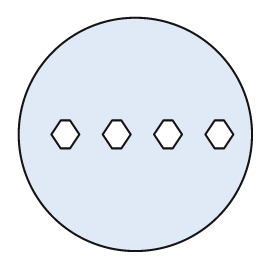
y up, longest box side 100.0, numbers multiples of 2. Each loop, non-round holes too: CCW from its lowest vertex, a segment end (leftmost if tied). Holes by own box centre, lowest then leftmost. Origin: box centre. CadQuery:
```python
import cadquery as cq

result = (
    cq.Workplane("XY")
    .moveTo(0.0, 0.0)
    .circle(50.0)
    .moveTo(-32.0, -6.0)
    .lineTo(-28.0, -6.0)
    .lineTo(-24.0, 0.0)
    .lineTo(-28.0, 6.0)
    .lineTo(-32.0, 6.0)
    .lineTo(-36.0, 0.0)
    .close()
    .moveTo(-10.0, -6.0)
    .lineTo(-6.0, -6.0)
    .lineTo(-2.0, 0.0)
    .lineTo(-6.0, 6.0)
    .lineTo(-10.0, 6.0)
    .lineTo(-14.0, 0.0)
    .close()
    .moveTo(12.0, -6.0)
    .lineTo(16.0, -6.0)
    .lineTo(20.0, 0.0)
    .lineTo(16.0, 6.0)
    .lineTo(12.0, 6.0)
    .lineTo(8.0, 0.0)
    .close()
    .moveTo(34.0, -6.0)
    .lineTo(38.0, -6.0)
    .lineTo(42.0, 0.0)
    .lineTo(38.0, 6.0)
    .lineTo(34.0, 6.0)
    .lineTo(30.0, 0.0)
    .close()
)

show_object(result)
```